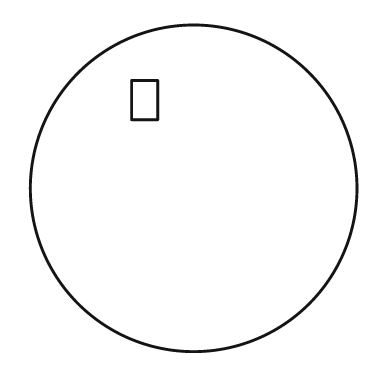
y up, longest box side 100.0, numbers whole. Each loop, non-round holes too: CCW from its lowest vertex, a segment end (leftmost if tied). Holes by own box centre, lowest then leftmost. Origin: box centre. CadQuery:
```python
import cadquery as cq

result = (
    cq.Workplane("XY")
    .moveTo(0.0, 0.0)
    .circle(50.0)
    .moveTo(-19.0, 21.0)
    .lineTo(-11.0, 21.0)
    .lineTo(-11.0, 33.0)
    .lineTo(-19.0, 33.0)
    .close()
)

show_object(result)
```